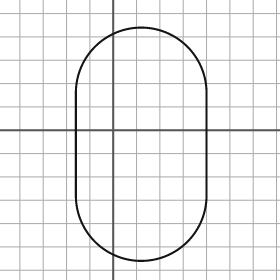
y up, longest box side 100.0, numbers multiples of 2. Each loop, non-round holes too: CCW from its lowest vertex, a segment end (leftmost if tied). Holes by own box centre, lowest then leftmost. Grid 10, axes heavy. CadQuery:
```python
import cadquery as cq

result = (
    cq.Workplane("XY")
    .moveTo(-16.0, -28.0)
    .threePointArc((12.0, -56.0), (40.0, -28.0))
    .lineTo(40.0, 16.0)
    .threePointArc((12.0, 44.0), (-16.0, 16.0))
    .close()
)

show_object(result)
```